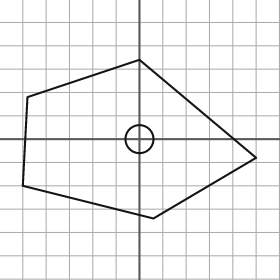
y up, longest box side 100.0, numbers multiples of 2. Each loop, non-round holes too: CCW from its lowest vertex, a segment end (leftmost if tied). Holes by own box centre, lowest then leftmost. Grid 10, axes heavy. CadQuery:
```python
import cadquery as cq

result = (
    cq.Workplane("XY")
    .moveTo(6.0, -34.0)
    .lineTo(50.0, -8.0)
    .lineTo(0.0, 34.0)
    .lineTo(-48.0, 18.0)
    .lineTo(-50.0, -20.0)
    .close()
    .moveTo(0.0, 0.0)
    .circle(6.0)
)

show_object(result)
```